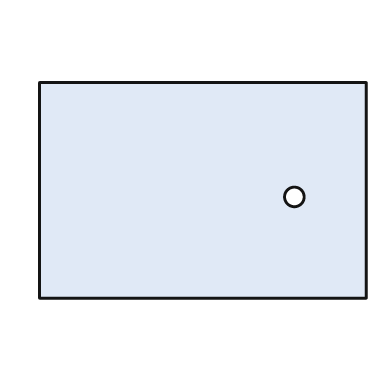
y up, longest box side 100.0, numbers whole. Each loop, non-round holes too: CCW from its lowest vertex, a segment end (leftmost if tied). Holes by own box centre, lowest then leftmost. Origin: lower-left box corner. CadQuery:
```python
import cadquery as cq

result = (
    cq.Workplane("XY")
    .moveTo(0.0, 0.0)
    .lineTo(100.0, 0.0)
    .lineTo(100.0, 66.0)
    .lineTo(0.0, 66.0)
    .close()
    .moveTo(78.0, 31.0)
    .circle(3.0)
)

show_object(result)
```